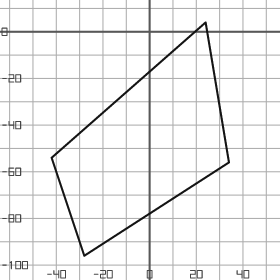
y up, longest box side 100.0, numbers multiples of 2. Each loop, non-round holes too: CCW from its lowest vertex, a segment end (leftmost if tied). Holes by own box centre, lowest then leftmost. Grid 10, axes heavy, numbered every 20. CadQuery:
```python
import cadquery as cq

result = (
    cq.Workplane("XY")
    .moveTo(-28.0, -96.0)
    .lineTo(34.0, -56.0)
    .lineTo(24.0, 4.0)
    .lineTo(-42.0, -54.0)
    .close()
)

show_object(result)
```